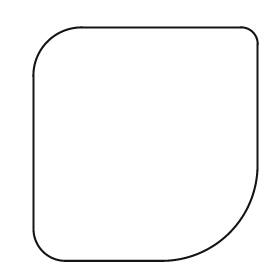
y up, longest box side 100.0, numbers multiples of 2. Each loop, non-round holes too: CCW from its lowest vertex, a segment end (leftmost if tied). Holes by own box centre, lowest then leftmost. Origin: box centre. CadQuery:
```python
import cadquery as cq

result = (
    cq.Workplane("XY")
    .moveTo(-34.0, -50.0)
    .lineTo(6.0, -50.0)
    .threePointArc((36.0, -38.0), (48.0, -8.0))
    .lineTo(48.0, 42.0)
    .threePointArc((46.0, 48.0), (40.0, 50.0))
    .lineTo(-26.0, 50.0)
    .threePointArc((-42.0, 44.0), (-48.0, 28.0))
    .lineTo(-48.0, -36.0)
    .threePointArc((-44.0, -46.0), (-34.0, -50.0))
    .close()
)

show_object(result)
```